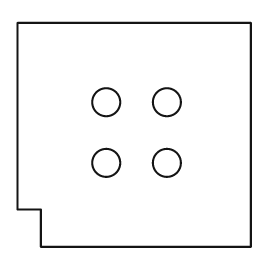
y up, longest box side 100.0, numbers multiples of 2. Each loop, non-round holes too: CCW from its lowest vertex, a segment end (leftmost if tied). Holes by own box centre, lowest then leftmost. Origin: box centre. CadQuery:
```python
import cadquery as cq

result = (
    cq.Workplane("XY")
    .moveTo(-40.0, -48.0)
    .lineTo(50.0, -48.0)
    .lineTo(50.0, 48.0)
    .lineTo(-50.0, 48.0)
    .lineTo(-50.0, -32.0)
    .lineTo(-40.0, -32.0)
    .close()
    .moveTo(-12.0, -12.0)
    .circle(6.0)
    .moveTo(14.0, -12.0)
    .circle(6.0)
    .moveTo(-12.0, 14.0)
    .circle(6.0)
    .moveTo(14.0, 14.0)
    .circle(6.0)
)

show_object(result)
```